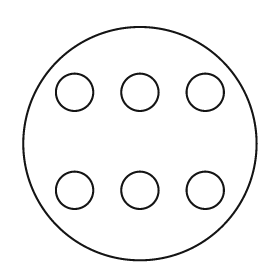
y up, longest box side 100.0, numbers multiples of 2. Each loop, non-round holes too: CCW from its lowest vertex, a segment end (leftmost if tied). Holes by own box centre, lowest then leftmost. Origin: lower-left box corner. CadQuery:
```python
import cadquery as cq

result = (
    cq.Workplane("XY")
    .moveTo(50.0, 50.0)
    .circle(50.0)
    .moveTo(22.0, 30.0)
    .circle(8.0)
    .moveTo(50.0, 30.0)
    .circle(8.0)
    .moveTo(78.0, 30.0)
    .circle(8.0)
    .moveTo(22.0, 72.0)
    .circle(8.0)
    .moveTo(50.0, 72.0)
    .circle(8.0)
    .moveTo(78.0, 72.0)
    .circle(8.0)
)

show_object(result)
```